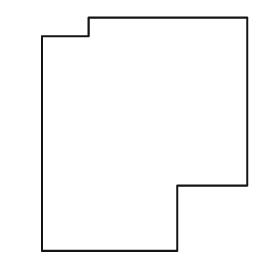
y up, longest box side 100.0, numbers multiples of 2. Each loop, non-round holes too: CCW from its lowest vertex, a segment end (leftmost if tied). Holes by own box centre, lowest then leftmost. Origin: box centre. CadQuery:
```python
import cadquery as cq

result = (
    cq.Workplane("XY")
    .moveTo(-44.0, -50.0)
    .lineTo(14.0, -50.0)
    .lineTo(14.0, -22.0)
    .lineTo(44.0, -22.0)
    .lineTo(44.0, 50.0)
    .lineTo(-24.0, 50.0)
    .lineTo(-24.0, 42.0)
    .lineTo(-44.0, 42.0)
    .close()
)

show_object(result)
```